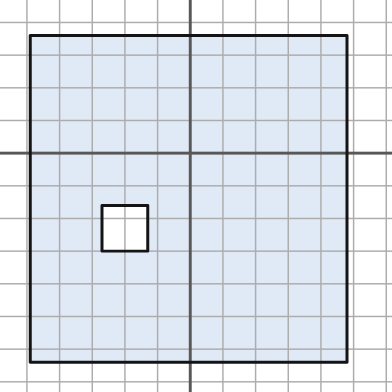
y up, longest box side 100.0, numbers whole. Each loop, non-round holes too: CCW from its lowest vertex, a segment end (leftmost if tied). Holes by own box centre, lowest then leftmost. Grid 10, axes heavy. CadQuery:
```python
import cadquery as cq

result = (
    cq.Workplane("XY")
    .moveTo(-49.0, -64.0)
    .lineTo(48.0, -64.0)
    .lineTo(48.0, 36.0)
    .lineTo(-49.0, 36.0)
    .close()
    .moveTo(-27.0, -30.0)
    .lineTo(-13.0, -30.0)
    .lineTo(-13.0, -16.0)
    .lineTo(-27.0, -16.0)
    .close()
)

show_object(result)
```